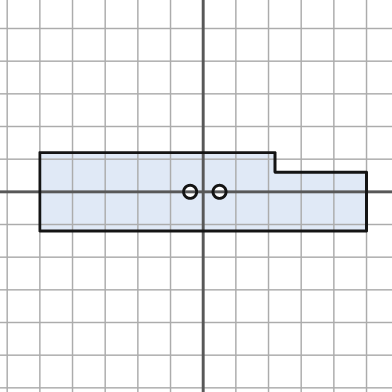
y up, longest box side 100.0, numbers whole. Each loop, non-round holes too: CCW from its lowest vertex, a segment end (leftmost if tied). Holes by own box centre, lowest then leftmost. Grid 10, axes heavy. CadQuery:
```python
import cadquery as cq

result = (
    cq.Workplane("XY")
    .moveTo(-50.0, -12.0)
    .lineTo(50.0, -12.0)
    .lineTo(50.0, 6.0)
    .lineTo(22.0, 6.0)
    .lineTo(22.0, 12.0)
    .lineTo(-50.0, 12.0)
    .close()
    .moveTo(-4.0, 0.0)
    .circle(2.0)
    .moveTo(5.0, 0.0)
    .circle(2.0)
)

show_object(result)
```